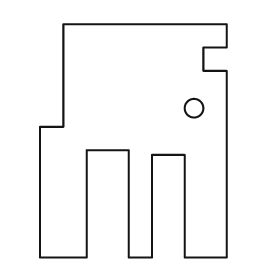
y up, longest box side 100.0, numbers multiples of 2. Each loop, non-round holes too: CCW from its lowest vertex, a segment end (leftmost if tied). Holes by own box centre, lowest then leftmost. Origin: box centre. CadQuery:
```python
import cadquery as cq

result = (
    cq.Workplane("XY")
    .moveTo(-40.0, -50.0)
    .lineTo(-20.0, -50.0)
    .lineTo(-20.0, -4.0)
    .lineTo(-2.0, -4.0)
    .lineTo(-2.0, -50.0)
    .lineTo(8.0, -50.0)
    .lineTo(8.0, -6.0)
    .lineTo(22.0, -6.0)
    .lineTo(22.0, -50.0)
    .lineTo(40.0, -50.0)
    .lineTo(40.0, 30.0)
    .lineTo(30.0, 30.0)
    .lineTo(30.0, 40.0)
    .lineTo(40.0, 40.0)
    .lineTo(40.0, 50.0)
    .lineTo(-30.0, 50.0)
    .lineTo(-30.0, 6.0)
    .lineTo(-40.0, 6.0)
    .close()
    .moveTo(26.0, 14.0)
    .circle(4.0)
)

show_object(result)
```